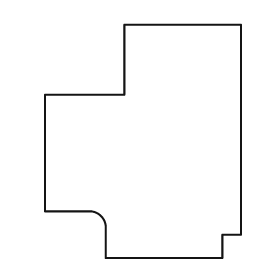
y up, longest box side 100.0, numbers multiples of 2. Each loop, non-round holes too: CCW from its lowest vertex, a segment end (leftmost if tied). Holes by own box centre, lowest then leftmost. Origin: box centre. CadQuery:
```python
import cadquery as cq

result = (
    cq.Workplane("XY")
    .moveTo(-16.0, -50.0)
    .lineTo(34.0, -50.0)
    .lineTo(34.0, -40.0)
    .lineTo(42.0, -40.0)
    .lineTo(42.0, 50.0)
    .lineTo(-8.0, 50.0)
    .lineTo(-8.0, 20.0)
    .lineTo(-42.0, 20.0)
    .lineTo(-42.0, -30.0)
    .lineTo(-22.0, -30.0)
    .threePointArc((-18.0, -32.0), (-16.0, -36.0))
    .close()
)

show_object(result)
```